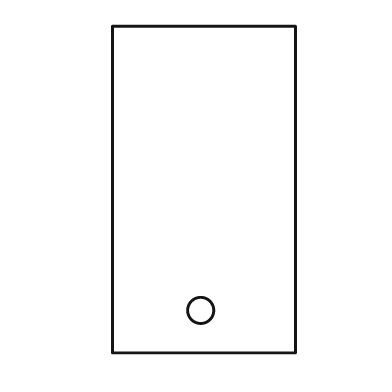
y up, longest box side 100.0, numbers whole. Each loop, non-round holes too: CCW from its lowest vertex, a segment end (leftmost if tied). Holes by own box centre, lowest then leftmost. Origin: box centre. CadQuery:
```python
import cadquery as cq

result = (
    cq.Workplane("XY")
    .moveTo(-28.0, -50.0)
    .lineTo(28.0, -50.0)
    .lineTo(28.0, 50.0)
    .lineTo(-28.0, 50.0)
    .close()
    .moveTo(-1.0, -37.0)
    .circle(4.0)
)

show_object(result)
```